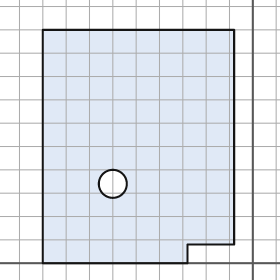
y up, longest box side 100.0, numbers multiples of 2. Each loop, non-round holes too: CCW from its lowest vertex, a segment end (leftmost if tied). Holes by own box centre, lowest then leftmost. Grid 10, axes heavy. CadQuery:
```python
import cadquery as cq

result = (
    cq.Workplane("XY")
    .moveTo(-90.0, 0.0)
    .lineTo(-28.0, 0.0)
    .lineTo(-28.0, 8.0)
    .lineTo(-8.0, 8.0)
    .lineTo(-8.0, 100.0)
    .lineTo(-90.0, 100.0)
    .close()
    .moveTo(-60.0, 34.0)
    .circle(6.0)
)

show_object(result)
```